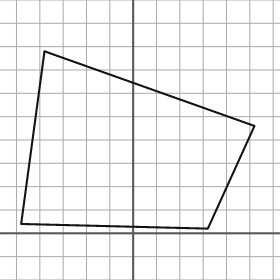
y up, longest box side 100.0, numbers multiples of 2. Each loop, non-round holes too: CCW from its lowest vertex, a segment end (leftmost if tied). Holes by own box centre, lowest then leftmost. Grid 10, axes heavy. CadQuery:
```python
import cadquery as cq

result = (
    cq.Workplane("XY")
    .moveTo(32.0, 2.0)
    .lineTo(52.0, 46.0)
    .lineTo(-38.0, 78.0)
    .lineTo(-48.0, 4.0)
    .close()
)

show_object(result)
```